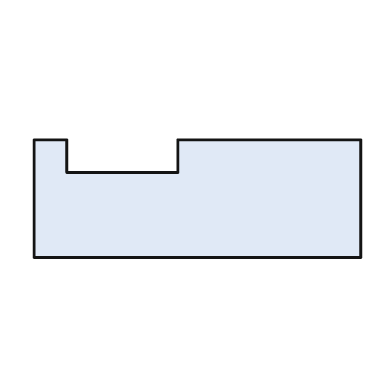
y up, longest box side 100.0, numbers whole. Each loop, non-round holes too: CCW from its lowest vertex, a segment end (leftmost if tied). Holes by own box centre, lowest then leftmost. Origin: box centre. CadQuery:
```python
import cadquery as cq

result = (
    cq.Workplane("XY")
    .moveTo(-50.0, -18.0)
    .lineTo(50.0, -18.0)
    .lineTo(50.0, 18.0)
    .lineTo(-6.0, 18.0)
    .lineTo(-6.0, 8.0)
    .lineTo(-40.0, 8.0)
    .lineTo(-40.0, 18.0)
    .lineTo(-50.0, 18.0)
    .close()
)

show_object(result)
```